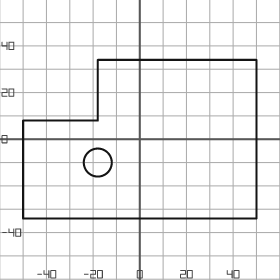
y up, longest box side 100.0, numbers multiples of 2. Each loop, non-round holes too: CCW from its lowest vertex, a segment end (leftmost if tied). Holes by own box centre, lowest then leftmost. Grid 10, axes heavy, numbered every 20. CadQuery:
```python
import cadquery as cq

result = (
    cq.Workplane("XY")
    .moveTo(-50.0, -34.0)
    .lineTo(50.0, -34.0)
    .lineTo(50.0, 34.0)
    .lineTo(-18.0, 34.0)
    .lineTo(-18.0, 8.0)
    .lineTo(-50.0, 8.0)
    .close()
    .moveTo(-18.0, -10.0)
    .circle(6.0)
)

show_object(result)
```